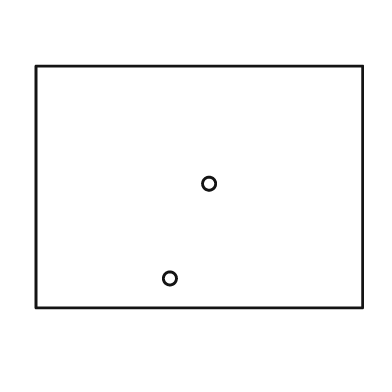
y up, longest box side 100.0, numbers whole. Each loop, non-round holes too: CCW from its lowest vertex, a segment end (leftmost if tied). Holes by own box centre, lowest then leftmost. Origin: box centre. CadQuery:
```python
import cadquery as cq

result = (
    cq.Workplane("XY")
    .moveTo(-50.0, -37.0)
    .lineTo(50.0, -37.0)
    .lineTo(50.0, 37.0)
    .lineTo(-50.0, 37.0)
    .close()
    .moveTo(-9.0, -28.0)
    .circle(2.0)
    .moveTo(3.0, 1.0)
    .circle(2.0)
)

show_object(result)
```